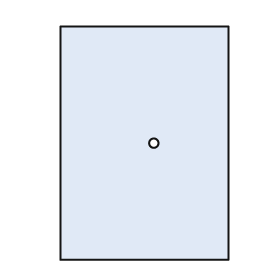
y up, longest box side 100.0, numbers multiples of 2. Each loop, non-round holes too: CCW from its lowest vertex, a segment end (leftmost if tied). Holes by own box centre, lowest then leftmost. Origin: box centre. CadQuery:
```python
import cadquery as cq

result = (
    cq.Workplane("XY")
    .moveTo(-36.0, -50.0)
    .lineTo(36.0, -50.0)
    .lineTo(36.0, 50.0)
    .lineTo(-36.0, 50.0)
    .close()
    .moveTo(4.0, 0.0)
    .circle(2.0)
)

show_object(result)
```